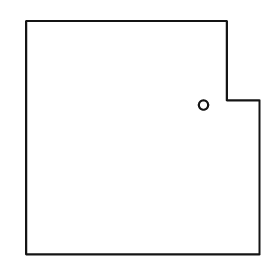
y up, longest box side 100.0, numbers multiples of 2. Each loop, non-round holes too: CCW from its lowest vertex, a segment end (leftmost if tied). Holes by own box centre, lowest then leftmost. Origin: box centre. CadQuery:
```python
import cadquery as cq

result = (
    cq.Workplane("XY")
    .moveTo(-50.0, -50.0)
    .lineTo(50.0, -50.0)
    .lineTo(50.0, 16.0)
    .lineTo(36.0, 16.0)
    .lineTo(36.0, 50.0)
    .lineTo(-50.0, 50.0)
    .close()
    .moveTo(26.0, 14.0)
    .circle(2.0)
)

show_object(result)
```